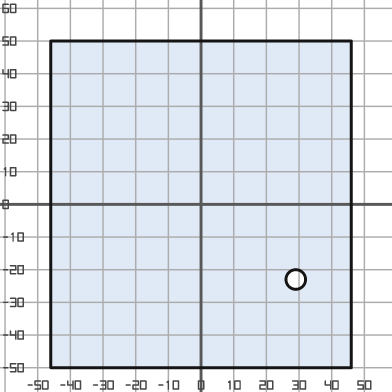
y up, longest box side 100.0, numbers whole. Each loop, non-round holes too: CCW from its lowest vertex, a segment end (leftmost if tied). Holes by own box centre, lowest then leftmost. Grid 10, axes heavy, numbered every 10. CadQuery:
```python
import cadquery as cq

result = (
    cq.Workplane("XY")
    .moveTo(-46.0, -50.0)
    .lineTo(46.0, -50.0)
    .lineTo(46.0, 50.0)
    .lineTo(-46.0, 50.0)
    .close()
    .moveTo(29.0, -23.0)
    .circle(3.0)
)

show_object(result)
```